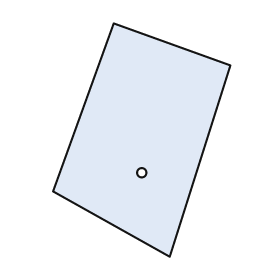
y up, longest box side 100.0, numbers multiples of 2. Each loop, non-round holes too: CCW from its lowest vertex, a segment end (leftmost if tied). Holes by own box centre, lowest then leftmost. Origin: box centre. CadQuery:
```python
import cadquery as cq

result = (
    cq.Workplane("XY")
    .moveTo(12.0, -50.0)
    .lineTo(38.0, 32.0)
    .lineTo(-12.0, 50.0)
    .lineTo(-38.0, -22.0)
    .close()
    .moveTo(0.0, -14.0)
    .circle(2.0)
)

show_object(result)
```